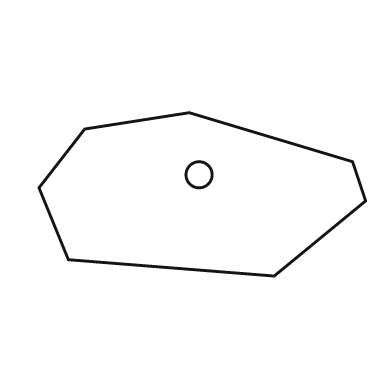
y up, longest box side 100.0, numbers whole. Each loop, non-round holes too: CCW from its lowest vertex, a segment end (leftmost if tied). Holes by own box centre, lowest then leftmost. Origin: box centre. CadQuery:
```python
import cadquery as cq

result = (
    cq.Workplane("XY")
    .moveTo(22.0, -25.0)
    .lineTo(50.0, -2.0)
    .lineTo(46.0, 10.0)
    .lineTo(-4.0, 25.0)
    .lineTo(-36.0, 20.0)
    .lineTo(-50.0, 2.0)
    .lineTo(-41.0, -20.0)
    .close()
    .moveTo(-1.0, 6.0)
    .circle(4.0)
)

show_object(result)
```